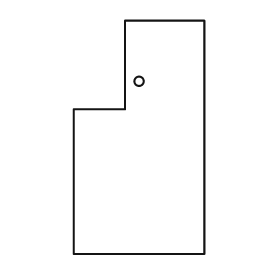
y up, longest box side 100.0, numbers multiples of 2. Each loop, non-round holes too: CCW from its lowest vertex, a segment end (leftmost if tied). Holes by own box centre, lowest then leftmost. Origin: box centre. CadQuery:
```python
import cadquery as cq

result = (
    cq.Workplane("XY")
    .moveTo(-28.0, -50.0)
    .lineTo(28.0, -50.0)
    .lineTo(28.0, 50.0)
    .lineTo(-6.0, 50.0)
    .lineTo(-6.0, 12.0)
    .lineTo(-28.0, 12.0)
    .close()
    .moveTo(0.0, 24.0)
    .circle(2.0)
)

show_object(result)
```